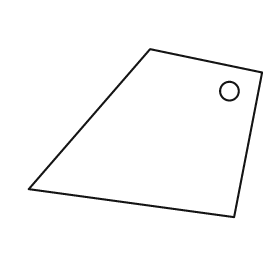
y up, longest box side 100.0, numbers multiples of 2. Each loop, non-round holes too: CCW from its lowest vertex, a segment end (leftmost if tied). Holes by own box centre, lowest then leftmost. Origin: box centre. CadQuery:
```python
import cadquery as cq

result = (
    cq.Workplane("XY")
    .moveTo(38.0, -36.0)
    .lineTo(50.0, 26.0)
    .lineTo(2.0, 36.0)
    .lineTo(-50.0, -24.0)
    .close()
    .moveTo(36.0, 18.0)
    .circle(4.0)
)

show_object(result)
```